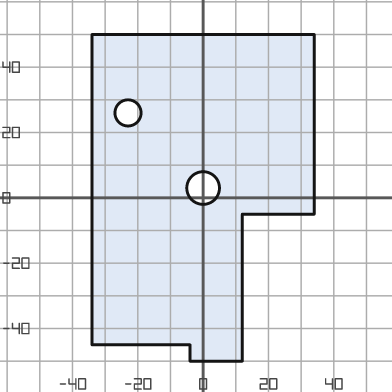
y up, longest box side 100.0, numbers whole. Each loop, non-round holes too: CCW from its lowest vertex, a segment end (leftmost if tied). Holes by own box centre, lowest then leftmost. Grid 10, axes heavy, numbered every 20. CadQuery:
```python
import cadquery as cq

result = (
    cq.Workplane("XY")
    .moveTo(-4.0, -50.0)
    .lineTo(12.0, -50.0)
    .lineTo(12.0, -5.0)
    .lineTo(34.0, -5.0)
    .lineTo(34.0, 50.0)
    .lineTo(-34.0, 50.0)
    .lineTo(-34.0, -45.0)
    .lineTo(-4.0, -45.0)
    .close()
    .moveTo(0.0, 3.0)
    .circle(5.0)
    .moveTo(-23.0, 26.0)
    .circle(4.0)
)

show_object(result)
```